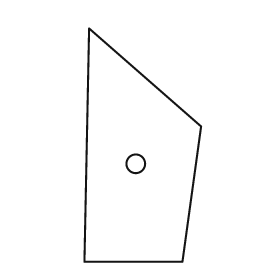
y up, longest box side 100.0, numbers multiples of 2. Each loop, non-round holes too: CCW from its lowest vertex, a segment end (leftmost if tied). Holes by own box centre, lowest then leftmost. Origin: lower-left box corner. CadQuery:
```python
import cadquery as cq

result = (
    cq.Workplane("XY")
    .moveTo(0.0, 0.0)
    .lineTo(42.0, 0.0)
    .lineTo(50.0, 58.0)
    .lineTo(2.0, 100.0)
    .close()
    .moveTo(22.0, 42.0)
    .circle(4.0)
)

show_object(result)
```